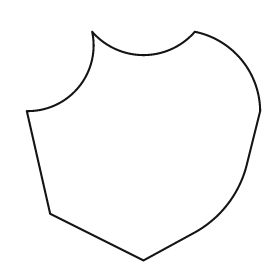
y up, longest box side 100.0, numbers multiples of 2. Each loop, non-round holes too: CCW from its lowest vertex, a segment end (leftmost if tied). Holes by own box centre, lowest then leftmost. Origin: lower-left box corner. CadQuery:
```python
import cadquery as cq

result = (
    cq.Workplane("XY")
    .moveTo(50.0, 0.0)
    .lineTo(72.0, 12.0)
    .threePointArc((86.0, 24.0), (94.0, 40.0))
    .lineTo(100.0, 64.0)
    .threePointArc((92.0, 86.0), (72.0, 98.0))
    .threePointArc((50.0, 88.0), (28.0, 98.0))
    .threePointArc((22.0, 74.0), (0.0, 64.0))
    .lineTo(10.0, 20.0)
    .close()
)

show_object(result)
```